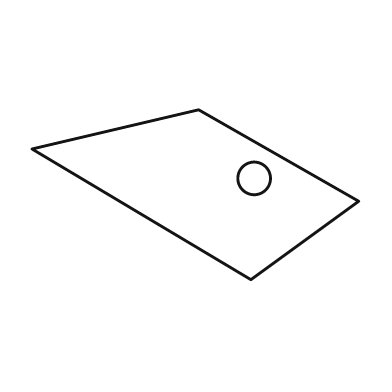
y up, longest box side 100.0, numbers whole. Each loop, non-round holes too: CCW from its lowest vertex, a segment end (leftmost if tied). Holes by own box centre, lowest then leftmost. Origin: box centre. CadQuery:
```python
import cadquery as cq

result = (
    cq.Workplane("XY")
    .moveTo(17.0, -26.0)
    .lineTo(50.0, -2.0)
    .lineTo(1.0, 26.0)
    .lineTo(-50.0, 14.0)
    .close()
    .moveTo(18.0, 5.0)
    .circle(5.0)
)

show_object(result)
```